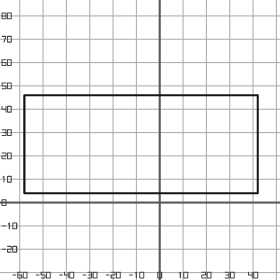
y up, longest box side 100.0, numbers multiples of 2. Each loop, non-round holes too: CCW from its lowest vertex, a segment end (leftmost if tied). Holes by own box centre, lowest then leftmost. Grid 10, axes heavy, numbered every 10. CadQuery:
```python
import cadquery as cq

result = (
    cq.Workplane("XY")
    .moveTo(-58.0, 4.0)
    .lineTo(42.0, 4.0)
    .lineTo(42.0, 46.0)
    .lineTo(-58.0, 46.0)
    .close()
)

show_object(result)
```